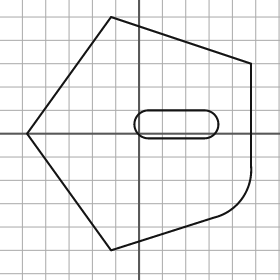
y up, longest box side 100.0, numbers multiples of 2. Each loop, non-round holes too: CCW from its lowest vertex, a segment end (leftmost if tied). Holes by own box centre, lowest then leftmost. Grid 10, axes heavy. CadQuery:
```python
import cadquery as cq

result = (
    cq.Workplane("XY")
    .moveTo(-12.0, -50.0)
    .lineTo(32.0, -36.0)
    .threePointArc((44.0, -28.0), (48.0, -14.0))
    .lineTo(48.0, 30.0)
    .lineTo(-12.0, 50.0)
    .lineTo(-48.0, 0.0)
    .close()
    .moveTo(4.0, -2.0)
    .lineTo(28.0, -2.0)
    .threePointArc((34.0, 4.0), (28.0, 10.0))
    .lineTo(4.0, 10.0)
    .threePointArc((-2.0, 4.0), (4.0, -2.0))
    .close()
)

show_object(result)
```